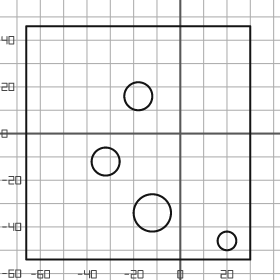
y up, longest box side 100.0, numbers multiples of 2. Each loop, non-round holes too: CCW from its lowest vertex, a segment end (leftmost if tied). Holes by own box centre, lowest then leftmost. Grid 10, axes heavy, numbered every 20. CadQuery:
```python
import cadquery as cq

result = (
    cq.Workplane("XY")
    .moveTo(-66.0, -54.0)
    .lineTo(30.0, -54.0)
    .lineTo(30.0, 46.0)
    .lineTo(-66.0, 46.0)
    .close()
    .moveTo(20.0, -46.0)
    .circle(4.0)
    .moveTo(-12.0, -34.0)
    .circle(8.0)
    .moveTo(-32.0, -12.0)
    .circle(6.0)
    .moveTo(-18.0, 16.0)
    .circle(6.0)
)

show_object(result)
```